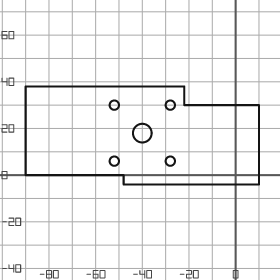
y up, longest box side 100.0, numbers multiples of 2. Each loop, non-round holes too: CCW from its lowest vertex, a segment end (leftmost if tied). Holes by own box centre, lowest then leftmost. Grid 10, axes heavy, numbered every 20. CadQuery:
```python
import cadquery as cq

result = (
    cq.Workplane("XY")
    .moveTo(-48.0, -4.0)
    .lineTo(10.0, -4.0)
    .lineTo(10.0, 30.0)
    .lineTo(-22.0, 30.0)
    .lineTo(-22.0, 38.0)
    .lineTo(-90.0, 38.0)
    .lineTo(-90.0, 0.0)
    .lineTo(-48.0, 0.0)
    .close()
    .moveTo(-52.0, 6.0)
    .circle(2.0)
    .moveTo(-28.0, 6.0)
    .circle(2.0)
    .moveTo(-40.0, 18.0)
    .circle(4.0)
    .moveTo(-52.0, 30.0)
    .circle(2.0)
    .moveTo(-28.0, 30.0)
    .circle(2.0)
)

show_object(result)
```